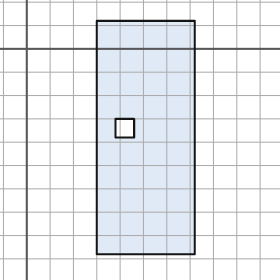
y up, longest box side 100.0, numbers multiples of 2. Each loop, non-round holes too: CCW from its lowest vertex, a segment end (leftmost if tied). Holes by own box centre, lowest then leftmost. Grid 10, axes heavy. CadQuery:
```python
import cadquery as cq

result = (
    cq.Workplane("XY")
    .moveTo(30.0, -88.0)
    .lineTo(72.0, -88.0)
    .lineTo(72.0, 12.0)
    .lineTo(30.0, 12.0)
    .close()
    .moveTo(38.0, -38.0)
    .lineTo(46.0, -38.0)
    .lineTo(46.0, -30.0)
    .lineTo(38.0, -30.0)
    .close()
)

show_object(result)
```